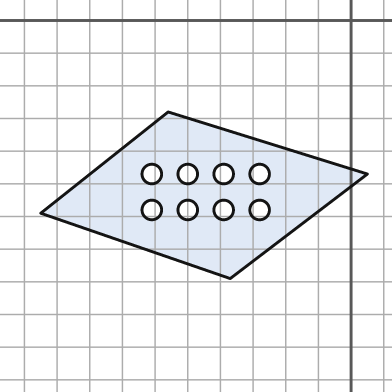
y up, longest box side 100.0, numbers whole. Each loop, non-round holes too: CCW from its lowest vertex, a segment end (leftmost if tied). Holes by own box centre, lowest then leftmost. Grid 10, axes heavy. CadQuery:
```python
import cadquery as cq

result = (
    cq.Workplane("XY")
    .moveTo(-37.0, -79.0)
    .lineTo(5.0, -47.0)
    .lineTo(-56.0, -28.0)
    .lineTo(-95.0, -59.0)
    .close()
    .moveTo(-61.0, -58.0)
    .circle(3.0)
    .moveTo(-50.0, -58.0)
    .circle(3.0)
    .moveTo(-39.0, -58.0)
    .circle(3.0)
    .moveTo(-28.0, -58.0)
    .circle(3.0)
    .moveTo(-61.0, -47.0)
    .circle(3.0)
    .moveTo(-50.0, -47.0)
    .circle(3.0)
    .moveTo(-39.0, -47.0)
    .circle(3.0)
    .moveTo(-28.0, -47.0)
    .circle(3.0)
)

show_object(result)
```